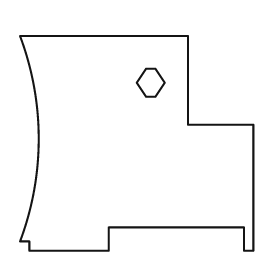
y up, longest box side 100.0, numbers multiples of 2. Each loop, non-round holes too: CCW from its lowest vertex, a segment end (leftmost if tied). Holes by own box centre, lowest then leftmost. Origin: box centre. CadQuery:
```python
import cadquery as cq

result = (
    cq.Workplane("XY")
    .moveTo(-46.0, -46.0)
    .lineTo(-12.0, -46.0)
    .lineTo(-12.0, -36.0)
    .lineTo(46.0, -36.0)
    .lineTo(46.0, -46.0)
    .lineTo(50.0, -46.0)
    .lineTo(50.0, 8.0)
    .lineTo(22.0, 8.0)
    .lineTo(22.0, 46.0)
    .lineTo(-50.0, 46.0)
    .threePointArc((-42.0, 2.0), (-50.0, -42.0))
    .lineTo(-46.0, -42.0)
    .close()
    .moveTo(4.0, 20.0)
    .lineTo(8.0, 20.0)
    .lineTo(12.0, 26.0)
    .lineTo(8.0, 32.0)
    .lineTo(4.0, 32.0)
    .lineTo(0.0, 26.0)
    .close()
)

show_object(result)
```